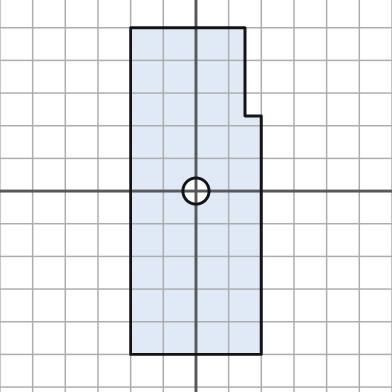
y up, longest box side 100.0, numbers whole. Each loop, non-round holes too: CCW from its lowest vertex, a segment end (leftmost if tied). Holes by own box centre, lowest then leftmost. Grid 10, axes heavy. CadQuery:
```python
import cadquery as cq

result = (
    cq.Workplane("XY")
    .moveTo(-20.0, -50.0)
    .lineTo(20.0, -50.0)
    .lineTo(20.0, 23.0)
    .lineTo(15.0, 23.0)
    .lineTo(15.0, 50.0)
    .lineTo(-20.0, 50.0)
    .close()
    .moveTo(0.0, 0.0)
    .circle(4.0)
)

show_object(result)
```